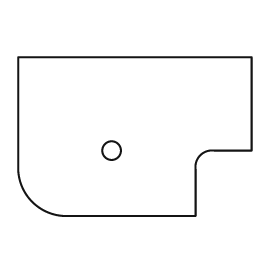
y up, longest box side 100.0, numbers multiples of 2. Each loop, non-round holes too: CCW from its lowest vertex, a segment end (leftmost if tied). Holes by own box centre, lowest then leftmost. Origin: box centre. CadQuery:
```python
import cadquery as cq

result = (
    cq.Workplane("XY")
    .moveTo(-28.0, -34.0)
    .lineTo(26.0, -34.0)
    .lineTo(26.0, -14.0)
    .threePointArc((28.0, -8.0), (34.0, -6.0))
    .lineTo(50.0, -6.0)
    .lineTo(50.0, 34.0)
    .lineTo(-50.0, 34.0)
    .lineTo(-50.0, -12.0)
    .threePointArc((-44.0, -28.0), (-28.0, -34.0))
    .close()
    .moveTo(-10.0, -6.0)
    .circle(4.0)
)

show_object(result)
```